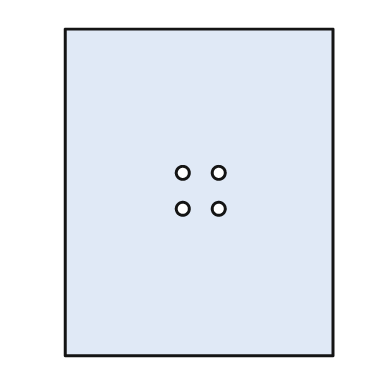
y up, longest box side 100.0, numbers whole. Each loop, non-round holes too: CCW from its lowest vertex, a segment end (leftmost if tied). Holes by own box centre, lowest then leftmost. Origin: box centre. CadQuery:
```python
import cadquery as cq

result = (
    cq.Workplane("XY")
    .moveTo(-41.0, -50.0)
    .lineTo(41.0, -50.0)
    .lineTo(41.0, 50.0)
    .lineTo(-41.0, 50.0)
    .close()
    .moveTo(-5.0, -5.0)
    .circle(2.0)
    .moveTo(6.0, -5.0)
    .circle(2.0)
    .moveTo(-5.0, 6.0)
    .circle(2.0)
    .moveTo(6.0, 6.0)
    .circle(2.0)
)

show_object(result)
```